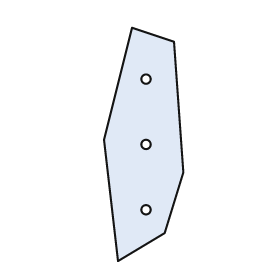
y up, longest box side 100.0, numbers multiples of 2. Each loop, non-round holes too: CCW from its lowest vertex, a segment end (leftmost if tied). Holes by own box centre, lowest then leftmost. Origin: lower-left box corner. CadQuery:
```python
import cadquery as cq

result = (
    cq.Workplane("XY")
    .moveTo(6.0, 0.0)
    .lineTo(26.0, 12.0)
    .lineTo(34.0, 38.0)
    .lineTo(30.0, 94.0)
    .lineTo(12.0, 100.0)
    .lineTo(0.0, 52.0)
    .close()
    .moveTo(18.0, 22.0)
    .circle(2.0)
    .moveTo(18.0, 50.0)
    .circle(2.0)
    .moveTo(18.0, 78.0)
    .circle(2.0)
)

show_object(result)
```